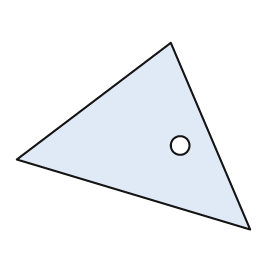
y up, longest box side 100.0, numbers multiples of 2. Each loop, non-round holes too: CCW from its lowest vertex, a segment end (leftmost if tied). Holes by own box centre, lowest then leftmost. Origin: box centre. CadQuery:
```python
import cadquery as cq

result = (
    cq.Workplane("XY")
    .moveTo(50.0, -40.0)
    .lineTo(16.0, 40.0)
    .lineTo(-50.0, -10.0)
    .close()
    .moveTo(20.0, -4.0)
    .circle(4.0)
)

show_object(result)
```